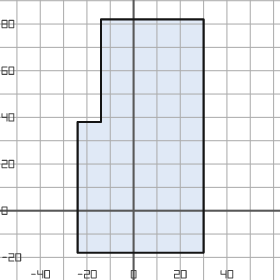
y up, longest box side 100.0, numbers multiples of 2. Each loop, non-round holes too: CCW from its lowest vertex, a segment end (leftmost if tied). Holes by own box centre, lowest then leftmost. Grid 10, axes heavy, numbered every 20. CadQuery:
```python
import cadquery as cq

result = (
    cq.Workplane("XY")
    .moveTo(-24.0, -18.0)
    .lineTo(30.0, -18.0)
    .lineTo(30.0, 82.0)
    .lineTo(-14.0, 82.0)
    .lineTo(-14.0, 38.0)
    .lineTo(-24.0, 38.0)
    .close()
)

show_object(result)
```